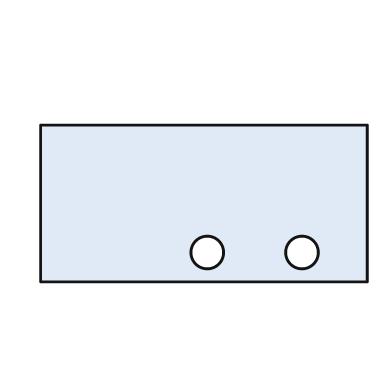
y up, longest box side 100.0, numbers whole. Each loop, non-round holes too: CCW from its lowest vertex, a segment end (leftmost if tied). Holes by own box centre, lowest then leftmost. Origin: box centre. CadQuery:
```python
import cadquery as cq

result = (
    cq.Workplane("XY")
    .moveTo(-50.0, -24.0)
    .lineTo(50.0, -24.0)
    .lineTo(50.0, 24.0)
    .lineTo(-50.0, 24.0)
    .close()
    .moveTo(1.0, -15.0)
    .circle(5.0)
    .moveTo(30.0, -15.0)
    .circle(5.0)
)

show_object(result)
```